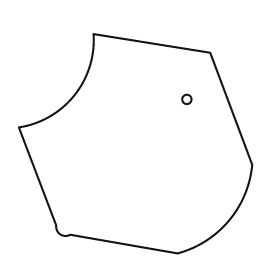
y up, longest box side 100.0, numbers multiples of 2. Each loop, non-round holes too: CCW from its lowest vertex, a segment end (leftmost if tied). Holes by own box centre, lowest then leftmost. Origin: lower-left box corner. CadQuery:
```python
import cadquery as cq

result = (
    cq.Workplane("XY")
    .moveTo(68.0, 0.0)
    .threePointArc((90.0, 14.0), (100.0, 38.0))
    .lineTo(82.0, 86.0)
    .lineTo(32.0, 94.0)
    .threePointArc((24.0, 68.0), (0.0, 54.0))
    .lineTo(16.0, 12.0)
    .threePointArc((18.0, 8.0), (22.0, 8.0))
    .close()
    .moveTo(72.0, 66.0)
    .circle(2.0)
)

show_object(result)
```